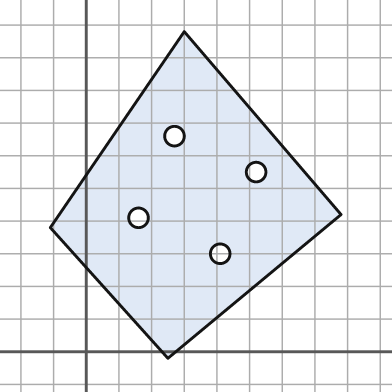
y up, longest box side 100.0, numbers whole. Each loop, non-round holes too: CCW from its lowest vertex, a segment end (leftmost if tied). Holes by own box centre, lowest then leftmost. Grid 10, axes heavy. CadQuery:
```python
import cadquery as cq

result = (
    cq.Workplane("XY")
    .moveTo(25.0, -2.0)
    .lineTo(78.0, 42.0)
    .lineTo(30.0, 98.0)
    .lineTo(-11.0, 38.0)
    .close()
    .moveTo(41.0, 30.0)
    .circle(3.0)
    .moveTo(16.0, 41.0)
    .circle(3.0)
    .moveTo(52.0, 55.0)
    .circle(3.0)
    .moveTo(27.0, 66.0)
    .circle(3.0)
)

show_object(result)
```